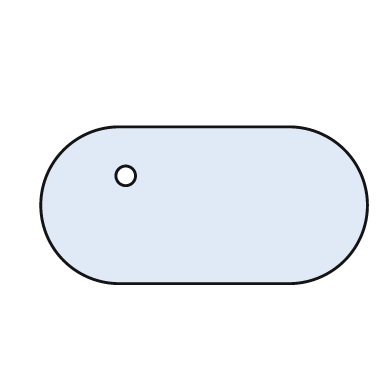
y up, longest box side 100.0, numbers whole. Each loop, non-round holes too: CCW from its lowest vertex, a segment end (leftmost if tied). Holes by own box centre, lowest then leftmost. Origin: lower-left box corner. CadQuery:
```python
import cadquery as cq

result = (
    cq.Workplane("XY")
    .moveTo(24.0, 0.0)
    .lineTo(76.0, 0.0)
    .threePointArc((100.0, 24.0), (76.0, 48.0))
    .lineTo(24.0, 48.0)
    .threePointArc((0.0, 24.0), (24.0, 0.0))
    .close()
    .moveTo(26.0, 33.0)
    .circle(3.0)
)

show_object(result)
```